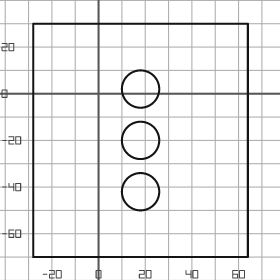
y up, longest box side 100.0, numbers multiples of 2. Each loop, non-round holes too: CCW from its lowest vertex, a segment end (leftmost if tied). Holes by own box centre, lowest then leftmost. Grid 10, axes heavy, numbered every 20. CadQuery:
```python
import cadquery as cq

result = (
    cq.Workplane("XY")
    .moveTo(-28.0, -70.0)
    .lineTo(64.0, -70.0)
    .lineTo(64.0, 30.0)
    .lineTo(-28.0, 30.0)
    .close()
    .moveTo(18.0, -42.0)
    .circle(8.0)
    .moveTo(18.0, -20.0)
    .circle(8.0)
    .moveTo(18.0, 2.0)
    .circle(8.0)
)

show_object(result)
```